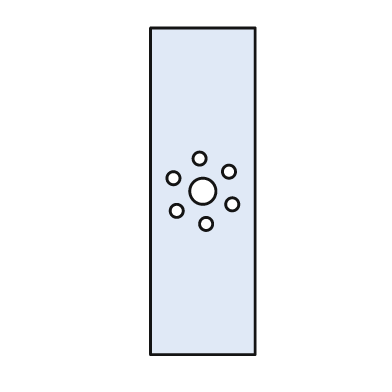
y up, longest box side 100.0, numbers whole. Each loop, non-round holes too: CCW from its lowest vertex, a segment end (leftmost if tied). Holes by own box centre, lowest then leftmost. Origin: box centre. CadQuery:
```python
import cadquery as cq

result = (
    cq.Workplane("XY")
    .moveTo(-16.0, -50.0)
    .lineTo(16.0, -50.0)
    .lineTo(16.0, 50.0)
    .lineTo(-16.0, 50.0)
    .close()
    .moveTo(1.0, -10.0)
    .circle(2.0)
    .moveTo(-8.0, -6.0)
    .circle(2.0)
    .moveTo(9.0, -4.0)
    .circle(2.0)
    .moveTo(0.0, 0.0)
    .circle(4.0)
    .moveTo(-9.0, 4.0)
    .circle(2.0)
    .moveTo(8.0, 6.0)
    .circle(2.0)
    .moveTo(-1.0, 10.0)
    .circle(2.0)
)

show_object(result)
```